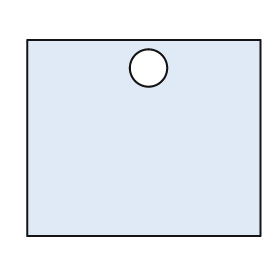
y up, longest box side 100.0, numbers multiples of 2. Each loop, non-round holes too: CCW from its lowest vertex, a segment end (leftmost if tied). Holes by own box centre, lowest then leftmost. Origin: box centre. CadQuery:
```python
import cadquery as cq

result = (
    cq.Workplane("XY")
    .moveTo(-50.0, -42.0)
    .lineTo(50.0, -42.0)
    .lineTo(50.0, 42.0)
    .lineTo(-50.0, 42.0)
    .close()
    .moveTo(2.0, 30.0)
    .circle(8.0)
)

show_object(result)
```